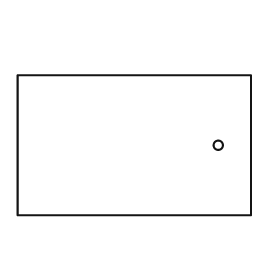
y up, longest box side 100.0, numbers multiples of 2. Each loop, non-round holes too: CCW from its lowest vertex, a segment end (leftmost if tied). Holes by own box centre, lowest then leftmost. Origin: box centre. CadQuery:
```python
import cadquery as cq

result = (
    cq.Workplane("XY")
    .moveTo(-50.0, -30.0)
    .lineTo(50.0, -30.0)
    .lineTo(50.0, 30.0)
    .lineTo(-50.0, 30.0)
    .close()
    .moveTo(36.0, 0.0)
    .circle(2.0)
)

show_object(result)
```